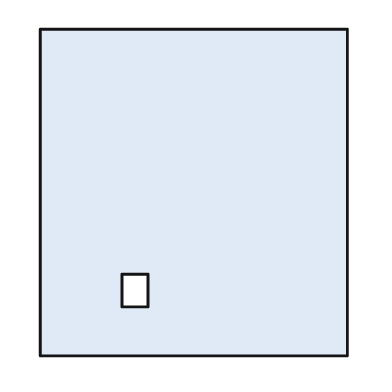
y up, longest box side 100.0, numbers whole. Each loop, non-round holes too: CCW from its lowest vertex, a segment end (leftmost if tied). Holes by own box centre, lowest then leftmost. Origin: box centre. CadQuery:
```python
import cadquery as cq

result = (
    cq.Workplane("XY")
    .moveTo(-47.0, -50.0)
    .lineTo(47.0, -50.0)
    .lineTo(47.0, 50.0)
    .lineTo(-47.0, 50.0)
    .close()
    .moveTo(-22.0, -35.0)
    .lineTo(-14.0, -35.0)
    .lineTo(-14.0, -25.0)
    .lineTo(-22.0, -25.0)
    .close()
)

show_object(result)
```